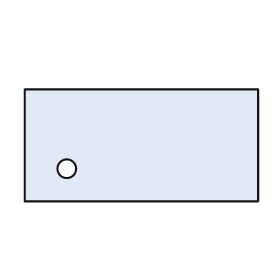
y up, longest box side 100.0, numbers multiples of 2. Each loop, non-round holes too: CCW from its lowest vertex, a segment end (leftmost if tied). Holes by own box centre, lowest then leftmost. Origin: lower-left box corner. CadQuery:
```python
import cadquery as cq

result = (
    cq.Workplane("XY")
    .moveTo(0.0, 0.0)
    .lineTo(100.0, 0.0)
    .lineTo(100.0, 48.0)
    .lineTo(0.0, 48.0)
    .close()
    .moveTo(18.0, 14.0)
    .circle(4.0)
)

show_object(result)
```